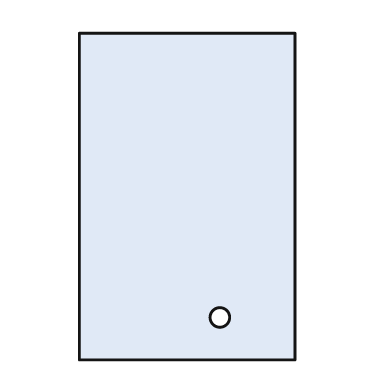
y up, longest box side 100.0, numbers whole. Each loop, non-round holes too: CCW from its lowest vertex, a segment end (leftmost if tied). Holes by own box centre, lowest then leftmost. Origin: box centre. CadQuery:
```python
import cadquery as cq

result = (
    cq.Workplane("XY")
    .moveTo(-33.0, -50.0)
    .lineTo(33.0, -50.0)
    .lineTo(33.0, 50.0)
    .lineTo(-33.0, 50.0)
    .close()
    .moveTo(10.0, -37.0)
    .circle(3.0)
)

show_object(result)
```